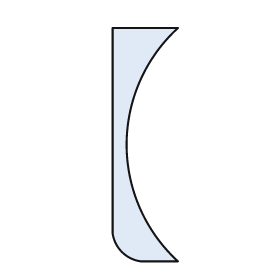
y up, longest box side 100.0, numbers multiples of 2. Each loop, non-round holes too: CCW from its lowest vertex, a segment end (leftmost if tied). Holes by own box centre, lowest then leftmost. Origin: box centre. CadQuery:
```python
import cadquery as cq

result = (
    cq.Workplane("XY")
    .moveTo(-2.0, -50.0)
    .lineTo(14.0, -50.0)
    .threePointArc((-8.0, 0.0), (14.0, 50.0))
    .lineTo(-14.0, 50.0)
    .lineTo(-14.0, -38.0)
    .threePointArc((-10.0, -46.0), (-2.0, -50.0))
    .close()
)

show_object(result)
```